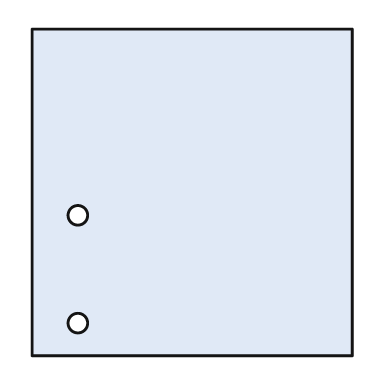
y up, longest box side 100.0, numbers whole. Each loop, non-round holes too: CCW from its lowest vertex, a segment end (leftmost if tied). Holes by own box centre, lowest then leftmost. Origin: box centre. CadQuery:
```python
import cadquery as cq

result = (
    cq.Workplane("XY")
    .moveTo(-49.0, -50.0)
    .lineTo(49.0, -50.0)
    .lineTo(49.0, 50.0)
    .lineTo(-49.0, 50.0)
    .close()
    .moveTo(-35.0, -40.0)
    .circle(3.0)
    .moveTo(-35.0, -7.0)
    .circle(3.0)
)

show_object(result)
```